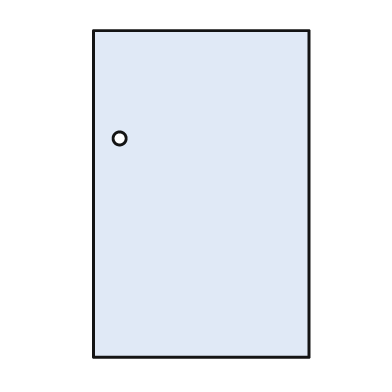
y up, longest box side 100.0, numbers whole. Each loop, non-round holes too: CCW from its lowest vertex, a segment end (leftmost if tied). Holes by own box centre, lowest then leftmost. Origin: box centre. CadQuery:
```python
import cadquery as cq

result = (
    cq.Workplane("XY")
    .moveTo(-33.0, -50.0)
    .lineTo(33.0, -50.0)
    .lineTo(33.0, 50.0)
    .lineTo(-33.0, 50.0)
    .close()
    .moveTo(-25.0, 17.0)
    .circle(2.0)
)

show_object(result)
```